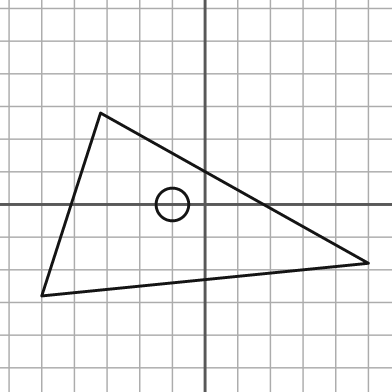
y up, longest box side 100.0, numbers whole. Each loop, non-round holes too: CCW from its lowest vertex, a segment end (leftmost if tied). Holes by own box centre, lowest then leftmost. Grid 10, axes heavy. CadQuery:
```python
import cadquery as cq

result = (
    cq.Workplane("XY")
    .moveTo(-50.0, -28.0)
    .lineTo(50.0, -18.0)
    .lineTo(-32.0, 28.0)
    .close()
    .moveTo(-10.0, 0.0)
    .circle(5.0)
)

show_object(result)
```